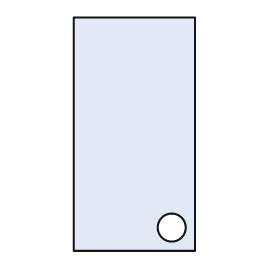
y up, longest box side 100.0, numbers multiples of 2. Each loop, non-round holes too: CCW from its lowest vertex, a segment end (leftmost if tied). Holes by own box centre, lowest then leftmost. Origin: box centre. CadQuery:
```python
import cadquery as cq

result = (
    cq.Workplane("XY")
    .moveTo(-26.0, -50.0)
    .lineTo(26.0, -50.0)
    .lineTo(26.0, 50.0)
    .lineTo(-26.0, 50.0)
    .close()
    .moveTo(16.0, -40.0)
    .circle(6.0)
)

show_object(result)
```